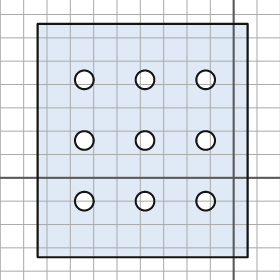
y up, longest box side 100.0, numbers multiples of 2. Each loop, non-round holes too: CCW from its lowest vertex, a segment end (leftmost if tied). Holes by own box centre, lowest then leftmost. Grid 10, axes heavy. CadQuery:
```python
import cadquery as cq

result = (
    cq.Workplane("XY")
    .moveTo(-84.0, -34.0)
    .lineTo(6.0, -34.0)
    .lineTo(6.0, 66.0)
    .lineTo(-84.0, 66.0)
    .close()
    .moveTo(-64.0, -10.0)
    .circle(4.0)
    .moveTo(-38.0, -10.0)
    .circle(4.0)
    .moveTo(-12.0, -10.0)
    .circle(4.0)
    .moveTo(-64.0, 16.0)
    .circle(4.0)
    .moveTo(-38.0, 16.0)
    .circle(4.0)
    .moveTo(-12.0, 16.0)
    .circle(4.0)
    .moveTo(-64.0, 42.0)
    .circle(4.0)
    .moveTo(-38.0, 42.0)
    .circle(4.0)
    .moveTo(-12.0, 42.0)
    .circle(4.0)
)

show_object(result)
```